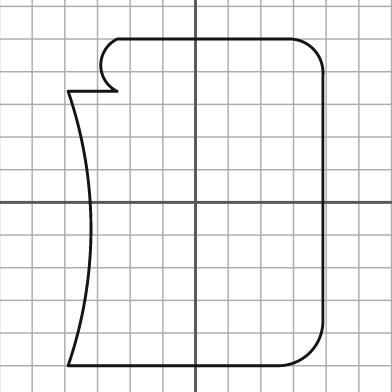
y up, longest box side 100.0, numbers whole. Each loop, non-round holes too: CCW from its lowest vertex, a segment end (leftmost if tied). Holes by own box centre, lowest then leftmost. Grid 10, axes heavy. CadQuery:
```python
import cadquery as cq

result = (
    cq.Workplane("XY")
    .moveTo(-39.0, -50.0)
    .lineTo(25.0, -50.0)
    .threePointArc((35.0, -46.0), (39.0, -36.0))
    .lineTo(39.0, 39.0)
    .threePointArc((36.0, 47.0), (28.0, 50.0))
    .lineTo(-24.0, 50.0)
    .threePointArc((-29.0, 42.0), (-24.0, 34.0))
    .lineTo(-39.0, 34.0)
    .threePointArc((-32.0, -8.0), (-39.0, -50.0))
    .close()
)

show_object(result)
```